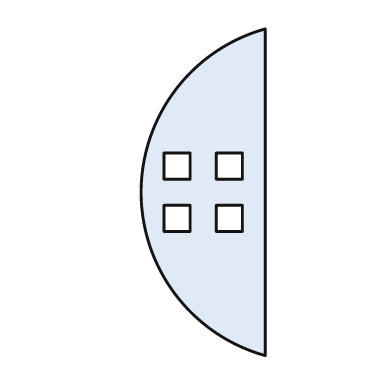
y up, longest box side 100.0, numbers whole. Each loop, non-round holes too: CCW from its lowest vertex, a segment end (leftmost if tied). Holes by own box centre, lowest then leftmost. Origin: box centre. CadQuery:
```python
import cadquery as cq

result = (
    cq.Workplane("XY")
    .moveTo(19.0, -50.0)
    .lineTo(19.0, 50.0)
    .threePointArc((-19.0, 0.0), (19.0, -50.0))
    .close()
    .moveTo(-12.0, -12.0)
    .lineTo(-4.0, -12.0)
    .lineTo(-4.0, -4.0)
    .lineTo(-12.0, -4.0)
    .close()
    .moveTo(4.0, -12.0)
    .lineTo(12.0, -12.0)
    .lineTo(12.0, -4.0)
    .lineTo(4.0, -4.0)
    .close()
    .moveTo(-12.0, 4.0)
    .lineTo(-4.0, 4.0)
    .lineTo(-4.0, 12.0)
    .lineTo(-12.0, 12.0)
    .close()
    .moveTo(4.0, 4.0)
    .lineTo(12.0, 4.0)
    .lineTo(12.0, 12.0)
    .lineTo(4.0, 12.0)
    .close()
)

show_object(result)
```